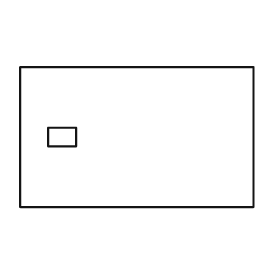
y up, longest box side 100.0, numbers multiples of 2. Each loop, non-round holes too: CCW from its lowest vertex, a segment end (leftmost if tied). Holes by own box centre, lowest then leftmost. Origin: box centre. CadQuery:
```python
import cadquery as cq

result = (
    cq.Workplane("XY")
    .moveTo(-50.0, -30.0)
    .lineTo(50.0, -30.0)
    .lineTo(50.0, 30.0)
    .lineTo(-50.0, 30.0)
    .close()
    .moveTo(-38.0, -4.0)
    .lineTo(-26.0, -4.0)
    .lineTo(-26.0, 4.0)
    .lineTo(-38.0, 4.0)
    .close()
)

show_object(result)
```